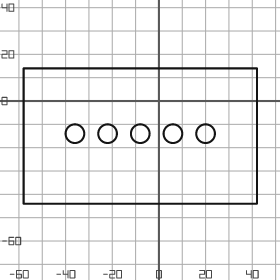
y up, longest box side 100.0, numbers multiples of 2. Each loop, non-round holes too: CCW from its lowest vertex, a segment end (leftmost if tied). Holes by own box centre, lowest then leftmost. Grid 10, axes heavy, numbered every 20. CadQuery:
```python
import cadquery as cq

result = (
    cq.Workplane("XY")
    .moveTo(-58.0, -44.0)
    .lineTo(42.0, -44.0)
    .lineTo(42.0, 14.0)
    .lineTo(-58.0, 14.0)
    .close()
    .moveTo(-36.0, -14.0)
    .circle(4.0)
    .moveTo(-22.0, -14.0)
    .circle(4.0)
    .moveTo(-8.0, -14.0)
    .circle(4.0)
    .moveTo(6.0, -14.0)
    .circle(4.0)
    .moveTo(20.0, -14.0)
    .circle(4.0)
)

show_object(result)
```